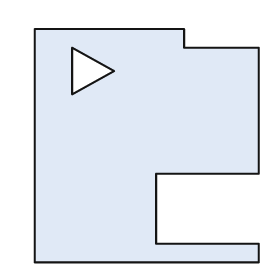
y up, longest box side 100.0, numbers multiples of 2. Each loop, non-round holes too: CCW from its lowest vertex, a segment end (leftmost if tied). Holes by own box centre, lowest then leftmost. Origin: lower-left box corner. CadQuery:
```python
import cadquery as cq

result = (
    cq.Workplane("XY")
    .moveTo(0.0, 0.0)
    .lineTo(96.0, 0.0)
    .lineTo(96.0, 8.0)
    .lineTo(52.0, 8.0)
    .lineTo(52.0, 38.0)
    .lineTo(96.0, 38.0)
    .lineTo(96.0, 92.0)
    .lineTo(64.0, 92.0)
    .lineTo(64.0, 100.0)
    .lineTo(0.0, 100.0)
    .close()
    .moveTo(16.0, 72.0)
    .lineTo(34.0, 82.0)
    .lineTo(16.0, 92.0)
    .close()
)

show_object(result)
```